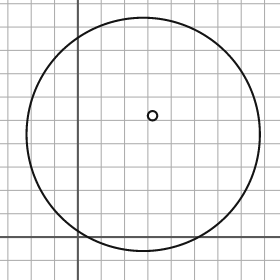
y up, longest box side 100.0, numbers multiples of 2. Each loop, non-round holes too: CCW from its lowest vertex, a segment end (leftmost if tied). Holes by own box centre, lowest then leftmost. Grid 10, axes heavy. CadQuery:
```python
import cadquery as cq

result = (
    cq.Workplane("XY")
    .moveTo(28.0, 44.0)
    .circle(50.0)
    .moveTo(32.0, 52.0)
    .circle(2.0)
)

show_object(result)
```